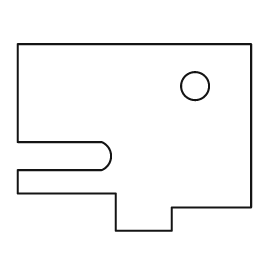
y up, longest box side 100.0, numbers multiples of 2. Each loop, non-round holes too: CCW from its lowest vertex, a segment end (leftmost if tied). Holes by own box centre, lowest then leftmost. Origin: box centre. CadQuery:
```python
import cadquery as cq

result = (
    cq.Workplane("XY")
    .moveTo(-8.0, -40.0)
    .lineTo(16.0, -40.0)
    .lineTo(16.0, -30.0)
    .lineTo(50.0, -30.0)
    .lineTo(50.0, 40.0)
    .lineTo(-50.0, 40.0)
    .lineTo(-50.0, -2.0)
    .lineTo(-14.0, -2.0)
    .threePointArc((-10.0, -8.0), (-14.0, -14.0))
    .lineTo(-50.0, -14.0)
    .lineTo(-50.0, -24.0)
    .lineTo(-8.0, -24.0)
    .close()
    .moveTo(26.0, 22.0)
    .circle(6.0)
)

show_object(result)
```